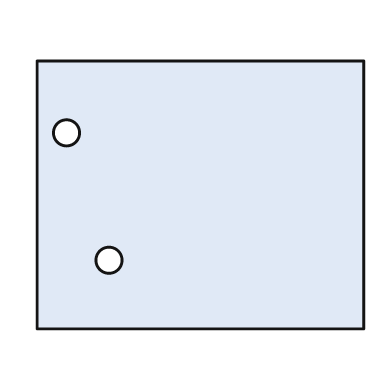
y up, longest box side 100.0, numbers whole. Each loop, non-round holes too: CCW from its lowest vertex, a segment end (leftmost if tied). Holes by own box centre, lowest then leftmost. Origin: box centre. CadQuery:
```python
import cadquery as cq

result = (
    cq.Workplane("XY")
    .moveTo(-50.0, -41.0)
    .lineTo(50.0, -41.0)
    .lineTo(50.0, 41.0)
    .lineTo(-50.0, 41.0)
    .close()
    .moveTo(-28.0, -20.0)
    .circle(4.0)
    .moveTo(-41.0, 19.0)
    .circle(4.0)
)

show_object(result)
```